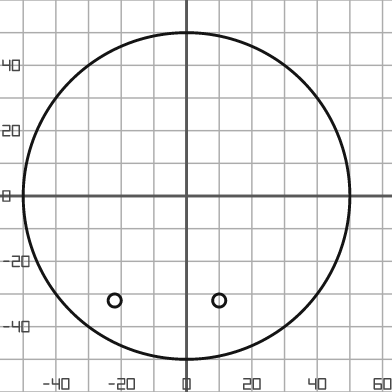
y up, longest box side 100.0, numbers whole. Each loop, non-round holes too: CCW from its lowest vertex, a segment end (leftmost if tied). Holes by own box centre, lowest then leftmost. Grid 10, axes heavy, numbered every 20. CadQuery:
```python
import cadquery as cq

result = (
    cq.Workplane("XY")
    .moveTo(0.0, 0.0)
    .circle(50.0)
    .moveTo(-22.0, -32.0)
    .circle(2.0)
    .moveTo(10.0, -32.0)
    .circle(2.0)
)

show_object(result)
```